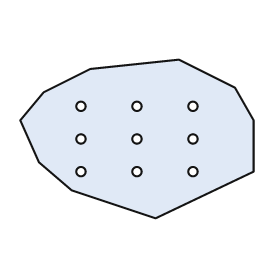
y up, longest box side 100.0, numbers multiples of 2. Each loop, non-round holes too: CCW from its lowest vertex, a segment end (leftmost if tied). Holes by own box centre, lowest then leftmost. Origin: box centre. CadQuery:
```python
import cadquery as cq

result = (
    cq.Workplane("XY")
    .moveTo(8.0, -34.0)
    .lineTo(50.0, -14.0)
    .lineTo(50.0, 8.0)
    .lineTo(42.0, 22.0)
    .lineTo(18.0, 34.0)
    .lineTo(-20.0, 30.0)
    .lineTo(-40.0, 20.0)
    .lineTo(-50.0, 8.0)
    .lineTo(-42.0, -10.0)
    .lineTo(-28.0, -22.0)
    .close()
    .moveTo(-24.0, -14.0)
    .circle(2.0)
    .moveTo(0.0, -14.0)
    .circle(2.0)
    .moveTo(24.0, -14.0)
    .circle(2.0)
    .moveTo(-24.0, 0.0)
    .circle(2.0)
    .moveTo(0.0, 0.0)
    .circle(2.0)
    .moveTo(24.0, 0.0)
    .circle(2.0)
    .moveTo(-24.0, 14.0)
    .circle(2.0)
    .moveTo(0.0, 14.0)
    .circle(2.0)
    .moveTo(24.0, 14.0)
    .circle(2.0)
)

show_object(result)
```